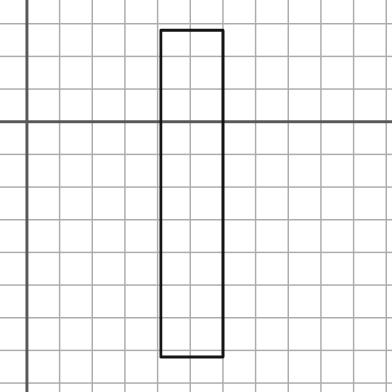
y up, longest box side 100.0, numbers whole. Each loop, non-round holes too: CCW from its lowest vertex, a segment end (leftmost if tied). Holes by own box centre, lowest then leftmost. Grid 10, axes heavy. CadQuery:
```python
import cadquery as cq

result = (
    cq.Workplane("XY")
    .moveTo(41.0, -72.0)
    .lineTo(60.0, -72.0)
    .lineTo(60.0, 28.0)
    .lineTo(41.0, 28.0)
    .close()
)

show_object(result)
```